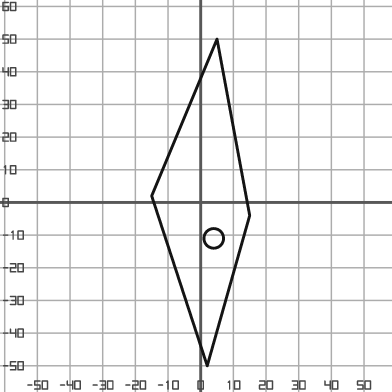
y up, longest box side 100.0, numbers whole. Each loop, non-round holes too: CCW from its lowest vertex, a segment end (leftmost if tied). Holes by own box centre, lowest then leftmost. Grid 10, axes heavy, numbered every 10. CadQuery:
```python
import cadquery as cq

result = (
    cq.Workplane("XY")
    .moveTo(2.0, -50.0)
    .lineTo(15.0, -4.0)
    .lineTo(5.0, 50.0)
    .lineTo(-15.0, 2.0)
    .close()
    .moveTo(4.0, -11.0)
    .circle(3.0)
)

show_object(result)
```